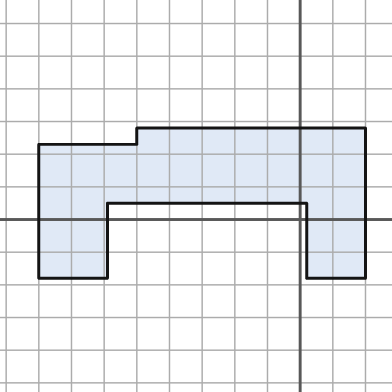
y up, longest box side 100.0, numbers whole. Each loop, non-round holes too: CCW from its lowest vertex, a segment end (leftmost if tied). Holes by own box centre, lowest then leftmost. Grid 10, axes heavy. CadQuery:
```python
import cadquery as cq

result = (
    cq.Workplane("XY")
    .moveTo(-80.0, -18.0)
    .lineTo(-59.0, -18.0)
    .lineTo(-59.0, 5.0)
    .lineTo(2.0, 5.0)
    .lineTo(2.0, -18.0)
    .lineTo(20.0, -18.0)
    .lineTo(20.0, 28.0)
    .lineTo(-50.0, 28.0)
    .lineTo(-50.0, 23.0)
    .lineTo(-80.0, 23.0)
    .close()
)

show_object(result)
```